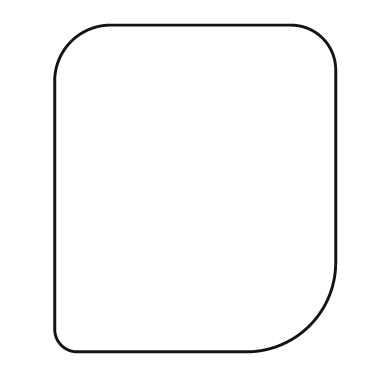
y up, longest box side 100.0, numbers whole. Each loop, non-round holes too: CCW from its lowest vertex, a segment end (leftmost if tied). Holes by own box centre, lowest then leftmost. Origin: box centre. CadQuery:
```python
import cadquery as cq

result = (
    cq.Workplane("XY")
    .moveTo(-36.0, -50.0)
    .lineTo(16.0, -50.0)
    .threePointArc((35.0, -42.0), (43.0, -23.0))
    .lineTo(43.0, 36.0)
    .threePointArc((39.0, 46.0), (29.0, 50.0))
    .lineTo(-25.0, 50.0)
    .threePointArc((-38.0, 45.0), (-43.0, 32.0))
    .lineTo(-43.0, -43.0)
    .threePointArc((-41.0, -48.0), (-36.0, -50.0))
    .close()
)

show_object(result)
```